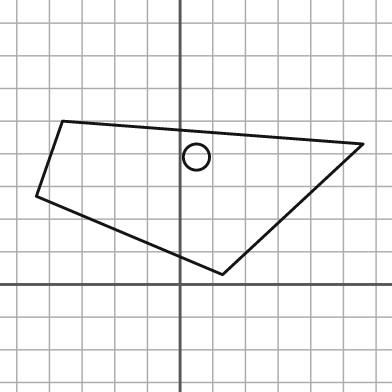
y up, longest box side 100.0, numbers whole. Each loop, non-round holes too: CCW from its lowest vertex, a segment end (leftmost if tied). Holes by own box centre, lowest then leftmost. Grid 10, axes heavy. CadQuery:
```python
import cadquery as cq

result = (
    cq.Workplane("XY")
    .moveTo(13.0, 3.0)
    .lineTo(56.0, 43.0)
    .lineTo(-36.0, 50.0)
    .lineTo(-44.0, 27.0)
    .close()
    .moveTo(5.0, 39.0)
    .circle(4.0)
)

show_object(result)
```